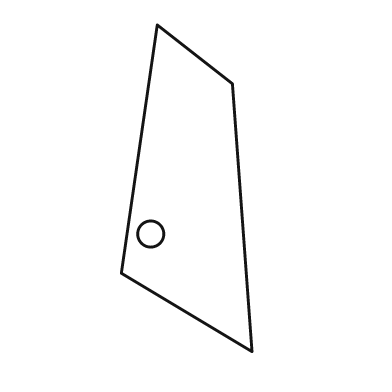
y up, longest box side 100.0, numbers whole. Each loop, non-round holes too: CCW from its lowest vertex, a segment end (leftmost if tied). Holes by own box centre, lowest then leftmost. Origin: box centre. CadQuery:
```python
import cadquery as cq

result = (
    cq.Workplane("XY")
    .moveTo(20.0, -50.0)
    .lineTo(14.0, 32.0)
    .lineTo(-9.0, 50.0)
    .lineTo(-20.0, -26.0)
    .close()
    .moveTo(-11.0, -14.0)
    .circle(4.0)
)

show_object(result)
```